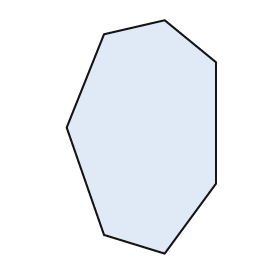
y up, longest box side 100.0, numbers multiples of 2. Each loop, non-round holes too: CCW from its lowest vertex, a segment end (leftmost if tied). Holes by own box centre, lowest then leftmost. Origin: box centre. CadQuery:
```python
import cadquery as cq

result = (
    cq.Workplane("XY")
    .moveTo(10.0, -50.0)
    .lineTo(32.0, -20.0)
    .lineTo(32.0, 32.0)
    .lineTo(10.0, 50.0)
    .lineTo(-16.0, 44.0)
    .lineTo(-32.0, 4.0)
    .lineTo(-16.0, -42.0)
    .close()
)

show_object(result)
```